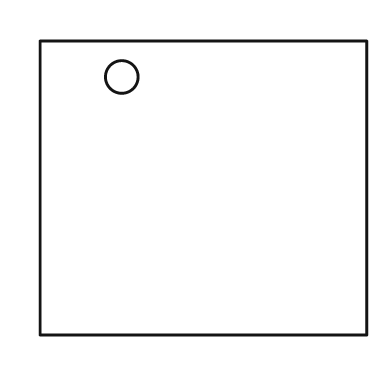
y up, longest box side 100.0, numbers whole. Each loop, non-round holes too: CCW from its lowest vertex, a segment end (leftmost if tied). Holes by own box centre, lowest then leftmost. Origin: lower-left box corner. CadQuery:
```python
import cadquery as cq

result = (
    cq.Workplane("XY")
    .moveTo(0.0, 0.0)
    .lineTo(100.0, 0.0)
    .lineTo(100.0, 90.0)
    .lineTo(0.0, 90.0)
    .close()
    .moveTo(25.0, 79.0)
    .circle(5.0)
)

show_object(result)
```